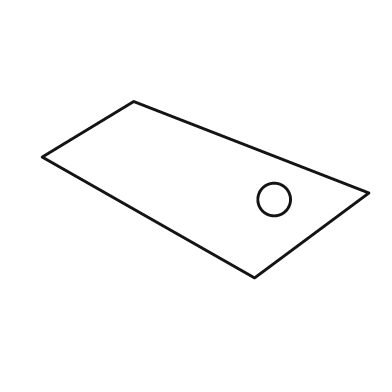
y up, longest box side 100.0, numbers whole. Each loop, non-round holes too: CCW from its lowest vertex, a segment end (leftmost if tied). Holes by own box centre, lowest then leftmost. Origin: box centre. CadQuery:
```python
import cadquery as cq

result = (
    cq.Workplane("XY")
    .moveTo(15.0, -27.0)
    .lineTo(50.0, -1.0)
    .lineTo(-22.0, 27.0)
    .lineTo(-50.0, 10.0)
    .close()
    .moveTo(21.0, -3.0)
    .circle(5.0)
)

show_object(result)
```